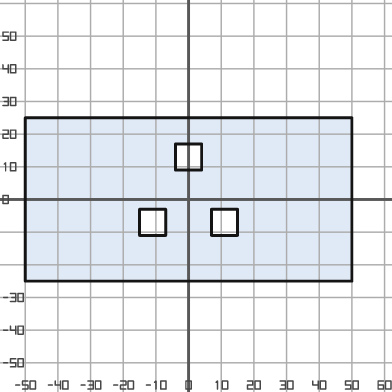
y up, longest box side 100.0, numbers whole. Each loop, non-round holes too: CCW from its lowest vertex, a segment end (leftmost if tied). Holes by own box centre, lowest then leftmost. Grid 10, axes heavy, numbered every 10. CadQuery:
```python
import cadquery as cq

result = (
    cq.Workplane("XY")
    .moveTo(-50.0, -25.0)
    .lineTo(50.0, -25.0)
    .lineTo(50.0, 25.0)
    .lineTo(-50.0, 25.0)
    .close()
    .moveTo(-15.0, -11.0)
    .lineTo(-7.0, -11.0)
    .lineTo(-7.0, -3.0)
    .lineTo(-15.0, -3.0)
    .close()
    .moveTo(7.0, -11.0)
    .lineTo(15.0, -11.0)
    .lineTo(15.0, -3.0)
    .lineTo(7.0, -3.0)
    .close()
    .moveTo(-4.0, 9.0)
    .lineTo(4.0, 9.0)
    .lineTo(4.0, 17.0)
    .lineTo(-4.0, 17.0)
    .close()
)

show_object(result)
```